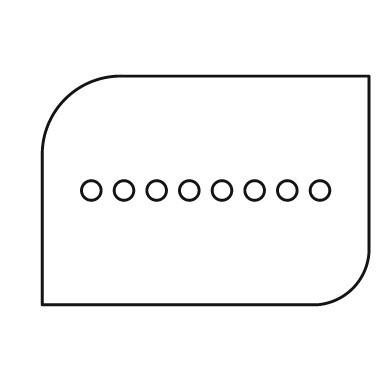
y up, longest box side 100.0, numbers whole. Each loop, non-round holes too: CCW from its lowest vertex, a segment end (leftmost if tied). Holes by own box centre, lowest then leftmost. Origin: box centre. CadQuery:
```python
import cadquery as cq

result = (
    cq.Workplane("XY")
    .moveTo(-50.0, -35.0)
    .lineTo(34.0, -35.0)
    .threePointArc((45.0, -30.0), (50.0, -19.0))
    .lineTo(50.0, 35.0)
    .lineTo(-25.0, 35.0)
    .threePointArc((-43.0, 28.0), (-50.0, 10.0))
    .close()
    .moveTo(-35.0, 0.0)
    .circle(3.0)
    .moveTo(-25.0, 0.0)
    .circle(3.0)
    .moveTo(-15.0, 0.0)
    .circle(3.0)
    .moveTo(-5.0, 0.0)
    .circle(3.0)
    .moveTo(5.0, 0.0)
    .circle(3.0)
    .moveTo(15.0, 0.0)
    .circle(3.0)
    .moveTo(25.0, 0.0)
    .circle(3.0)
    .moveTo(35.0, 0.0)
    .circle(3.0)
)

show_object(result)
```